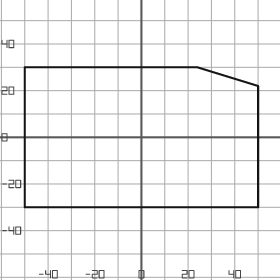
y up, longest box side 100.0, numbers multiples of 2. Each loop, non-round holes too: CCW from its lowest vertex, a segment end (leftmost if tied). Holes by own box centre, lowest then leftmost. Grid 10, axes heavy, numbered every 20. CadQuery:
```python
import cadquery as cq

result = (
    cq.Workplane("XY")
    .moveTo(-50.0, -30.0)
    .lineTo(50.0, -30.0)
    .lineTo(50.0, 22.0)
    .lineTo(24.0, 30.0)
    .lineTo(-50.0, 30.0)
    .close()
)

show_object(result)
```